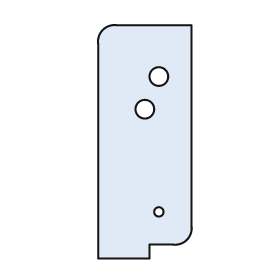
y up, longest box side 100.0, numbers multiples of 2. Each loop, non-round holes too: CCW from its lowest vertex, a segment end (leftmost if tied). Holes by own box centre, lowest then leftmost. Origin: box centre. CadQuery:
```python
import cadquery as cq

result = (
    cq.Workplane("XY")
    .moveTo(-20.0, -50.0)
    .lineTo(2.0, -50.0)
    .lineTo(2.0, -44.0)
    .lineTo(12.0, -44.0)
    .threePointArc((18.0, -42.0), (20.0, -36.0))
    .lineTo(20.0, 50.0)
    .lineTo(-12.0, 50.0)
    .threePointArc((-18.0, 48.0), (-20.0, 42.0))
    .close()
    .moveTo(6.0, -30.0)
    .circle(2.0)
    .moveTo(0.0, 14.0)
    .circle(4.0)
    .moveTo(6.0, 28.0)
    .circle(4.0)
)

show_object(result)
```